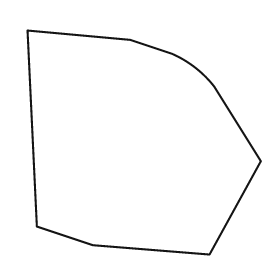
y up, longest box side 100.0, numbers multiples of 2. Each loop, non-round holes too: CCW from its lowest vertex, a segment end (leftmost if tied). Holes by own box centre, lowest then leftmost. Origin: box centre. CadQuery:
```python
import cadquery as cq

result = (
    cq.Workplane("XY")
    .moveTo(28.0, -48.0)
    .lineTo(50.0, -8.0)
    .lineTo(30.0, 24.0)
    .threePointArc((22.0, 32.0), (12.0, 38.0))
    .lineTo(-6.0, 44.0)
    .lineTo(-50.0, 48.0)
    .lineTo(-46.0, -36.0)
    .lineTo(-22.0, -44.0)
    .close()
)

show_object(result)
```